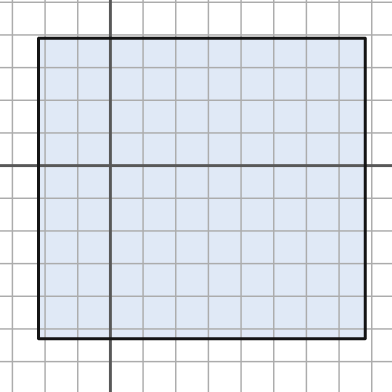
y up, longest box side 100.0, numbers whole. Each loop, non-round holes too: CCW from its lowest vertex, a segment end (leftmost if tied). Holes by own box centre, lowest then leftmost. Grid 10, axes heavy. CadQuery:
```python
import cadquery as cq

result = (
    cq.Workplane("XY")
    .moveTo(-22.0, -53.0)
    .lineTo(78.0, -53.0)
    .lineTo(78.0, 39.0)
    .lineTo(-22.0, 39.0)
    .close()
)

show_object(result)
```